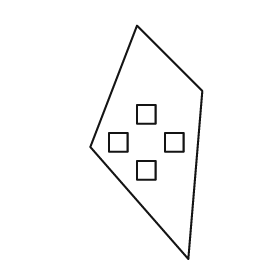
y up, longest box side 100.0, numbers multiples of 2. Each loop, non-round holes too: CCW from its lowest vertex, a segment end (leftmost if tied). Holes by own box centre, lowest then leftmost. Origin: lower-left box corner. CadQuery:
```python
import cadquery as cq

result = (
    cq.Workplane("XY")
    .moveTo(42.0, 0.0)
    .lineTo(48.0, 72.0)
    .lineTo(20.0, 100.0)
    .lineTo(0.0, 48.0)
    .close()
    .moveTo(20.0, 34.0)
    .lineTo(28.0, 34.0)
    .lineTo(28.0, 42.0)
    .lineTo(20.0, 42.0)
    .close()
    .moveTo(8.0, 46.0)
    .lineTo(16.0, 46.0)
    .lineTo(16.0, 54.0)
    .lineTo(8.0, 54.0)
    .close()
    .moveTo(32.0, 46.0)
    .lineTo(40.0, 46.0)
    .lineTo(40.0, 54.0)
    .lineTo(32.0, 54.0)
    .close()
    .moveTo(20.0, 58.0)
    .lineTo(28.0, 58.0)
    .lineTo(28.0, 66.0)
    .lineTo(20.0, 66.0)
    .close()
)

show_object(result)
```